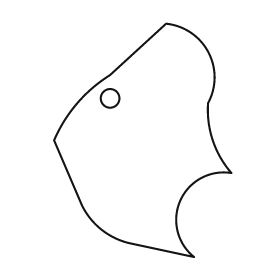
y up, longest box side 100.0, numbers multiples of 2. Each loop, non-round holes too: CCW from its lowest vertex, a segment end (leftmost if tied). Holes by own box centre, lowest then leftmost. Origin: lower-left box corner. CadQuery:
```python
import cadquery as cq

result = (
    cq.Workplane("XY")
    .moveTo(60.0, 0.0)
    .threePointArc((54.0, 24.0), (76.0, 36.0))
    .threePointArc((68.0, 50.0), (66.0, 66.0))
    .threePointArc((66.0, 88.0), (48.0, 100.0))
    .lineTo(24.0, 78.0)
    .threePointArc((10.0, 66.0), (0.0, 50.0))
    .lineTo(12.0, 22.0)
    .threePointArc((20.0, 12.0), (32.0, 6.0))
    .close()
    .moveTo(24.0, 68.0)
    .circle(4.0)
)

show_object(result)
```